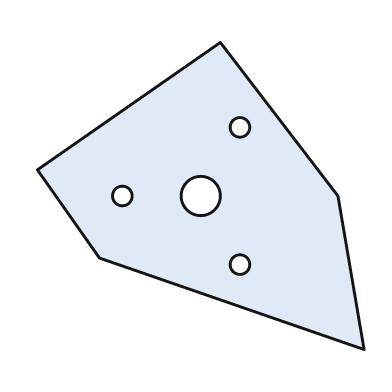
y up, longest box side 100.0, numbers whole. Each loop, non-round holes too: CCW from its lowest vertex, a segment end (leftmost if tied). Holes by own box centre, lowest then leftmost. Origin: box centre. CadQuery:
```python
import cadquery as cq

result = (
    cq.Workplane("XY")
    .moveTo(50.0, -47.0)
    .lineTo(42.0, 0.0)
    .lineTo(6.0, 47.0)
    .lineTo(-50.0, 8.0)
    .lineTo(-31.0, -19.0)
    .close()
    .moveTo(12.0, -21.0)
    .circle(3.0)
    .moveTo(-24.0, 0.0)
    .circle(3.0)
    .moveTo(0.0, 0.0)
    .circle(6.0)
    .moveTo(12.0, 21.0)
    .circle(3.0)
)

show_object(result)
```